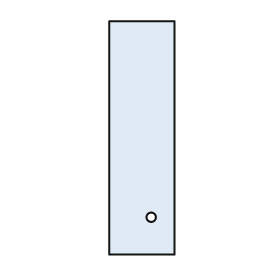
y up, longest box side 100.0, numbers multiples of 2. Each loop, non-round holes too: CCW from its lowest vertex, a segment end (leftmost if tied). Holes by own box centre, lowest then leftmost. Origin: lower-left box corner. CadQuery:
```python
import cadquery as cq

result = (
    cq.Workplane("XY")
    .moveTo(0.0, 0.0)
    .lineTo(28.0, 0.0)
    .lineTo(28.0, 100.0)
    .lineTo(0.0, 100.0)
    .close()
    .moveTo(18.0, 16.0)
    .circle(2.0)
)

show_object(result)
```